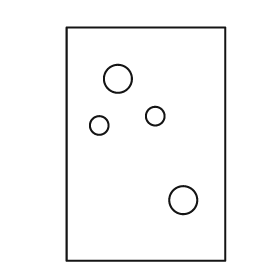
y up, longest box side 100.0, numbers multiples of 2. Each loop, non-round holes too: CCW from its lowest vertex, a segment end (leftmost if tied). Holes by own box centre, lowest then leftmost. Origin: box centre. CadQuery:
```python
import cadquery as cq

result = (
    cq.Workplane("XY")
    .moveTo(-34.0, -50.0)
    .lineTo(34.0, -50.0)
    .lineTo(34.0, 50.0)
    .lineTo(-34.0, 50.0)
    .close()
    .moveTo(16.0, -24.0)
    .circle(6.0)
    .moveTo(-20.0, 8.0)
    .circle(4.0)
    .moveTo(4.0, 12.0)
    .circle(4.0)
    .moveTo(-12.0, 28.0)
    .circle(6.0)
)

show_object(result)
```